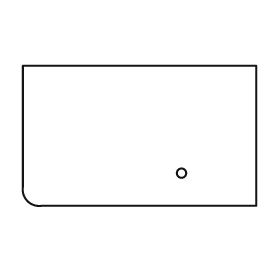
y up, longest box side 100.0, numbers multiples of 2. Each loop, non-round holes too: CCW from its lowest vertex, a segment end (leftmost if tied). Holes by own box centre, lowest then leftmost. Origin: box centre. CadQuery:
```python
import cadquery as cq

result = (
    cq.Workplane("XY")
    .moveTo(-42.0, -30.0)
    .lineTo(50.0, -30.0)
    .lineTo(50.0, 30.0)
    .lineTo(-50.0, 30.0)
    .lineTo(-50.0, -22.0)
    .threePointArc((-48.0, -28.0), (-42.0, -30.0))
    .close()
    .moveTo(18.0, -16.0)
    .circle(2.0)
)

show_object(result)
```